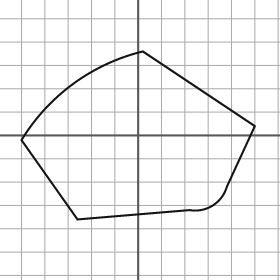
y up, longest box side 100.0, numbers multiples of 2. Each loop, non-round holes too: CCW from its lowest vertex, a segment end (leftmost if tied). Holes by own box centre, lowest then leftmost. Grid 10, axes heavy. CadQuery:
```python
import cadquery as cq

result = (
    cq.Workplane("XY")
    .moveTo(-26.0, -36.0)
    .lineTo(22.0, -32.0)
    .threePointArc((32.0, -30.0), (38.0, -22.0))
    .lineTo(50.0, 4.0)
    .lineTo(2.0, 36.0)
    .threePointArc((-28.0, 22.0), (-50.0, -2.0))
    .close()
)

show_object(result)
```